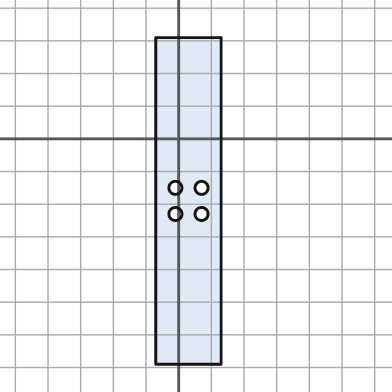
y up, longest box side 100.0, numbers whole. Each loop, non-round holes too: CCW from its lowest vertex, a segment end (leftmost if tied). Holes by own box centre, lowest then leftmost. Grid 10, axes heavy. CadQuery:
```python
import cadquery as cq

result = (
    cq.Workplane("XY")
    .moveTo(-7.0, -69.0)
    .lineTo(13.0, -69.0)
    .lineTo(13.0, 31.0)
    .lineTo(-7.0, 31.0)
    .close()
    .moveTo(-1.0, -23.0)
    .circle(2.0)
    .moveTo(7.0, -23.0)
    .circle(2.0)
    .moveTo(-1.0, -15.0)
    .circle(2.0)
    .moveTo(7.0, -15.0)
    .circle(2.0)
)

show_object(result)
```